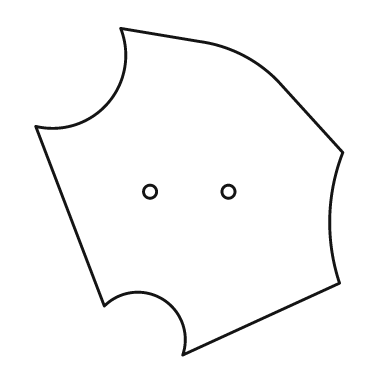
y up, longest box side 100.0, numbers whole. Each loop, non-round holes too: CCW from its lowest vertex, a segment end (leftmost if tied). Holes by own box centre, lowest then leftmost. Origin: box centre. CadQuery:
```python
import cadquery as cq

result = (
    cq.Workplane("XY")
    .moveTo(-2.0, -50.0)
    .lineTo(46.0, -28.0)
    .threePointArc((43.0, -8.0), (47.0, 12.0))
    .lineTo(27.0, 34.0)
    .threePointArc((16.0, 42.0), (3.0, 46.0))
    .lineTo(-21.0, 50.0)
    .threePointArc((-25.0, 27.0), (-47.0, 20.0))
    .lineTo(-26.0, -35.0)
    .threePointArc((-8.0, -33.0), (-2.0, -50.0))
    .close()
    .moveTo(-12.0, 0.0)
    .circle(2.0)
    .moveTo(12.0, 0.0)
    .circle(2.0)
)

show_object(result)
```